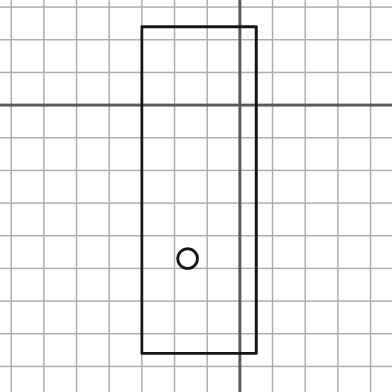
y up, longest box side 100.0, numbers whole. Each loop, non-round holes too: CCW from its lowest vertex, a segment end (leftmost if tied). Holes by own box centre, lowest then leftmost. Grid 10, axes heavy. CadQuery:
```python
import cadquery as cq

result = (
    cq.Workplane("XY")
    .moveTo(-30.0, -76.0)
    .lineTo(5.0, -76.0)
    .lineTo(5.0, 24.0)
    .lineTo(-30.0, 24.0)
    .close()
    .moveTo(-16.0, -47.0)
    .circle(3.0)
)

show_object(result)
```